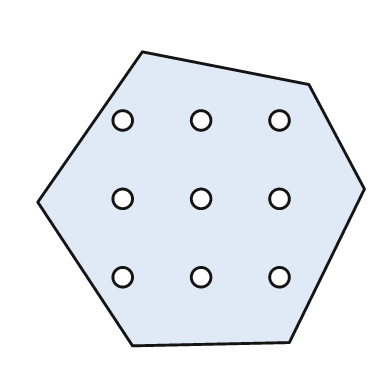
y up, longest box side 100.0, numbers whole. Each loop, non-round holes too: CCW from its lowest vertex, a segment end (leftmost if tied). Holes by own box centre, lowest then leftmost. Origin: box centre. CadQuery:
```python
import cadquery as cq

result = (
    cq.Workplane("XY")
    .moveTo(-21.0, -45.0)
    .lineTo(27.0, -44.0)
    .lineTo(50.0, 3.0)
    .lineTo(33.0, 35.0)
    .lineTo(-18.0, 45.0)
    .lineTo(-50.0, -1.0)
    .close()
    .moveTo(-24.0, -24.0)
    .circle(3.0)
    .moveTo(0.0, -24.0)
    .circle(3.0)
    .moveTo(24.0, -24.0)
    .circle(3.0)
    .moveTo(-24.0, 0.0)
    .circle(3.0)
    .moveTo(0.0, 0.0)
    .circle(3.0)
    .moveTo(24.0, 0.0)
    .circle(3.0)
    .moveTo(-24.0, 24.0)
    .circle(3.0)
    .moveTo(0.0, 24.0)
    .circle(3.0)
    .moveTo(24.0, 24.0)
    .circle(3.0)
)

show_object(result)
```